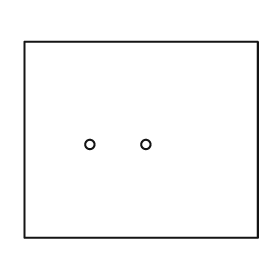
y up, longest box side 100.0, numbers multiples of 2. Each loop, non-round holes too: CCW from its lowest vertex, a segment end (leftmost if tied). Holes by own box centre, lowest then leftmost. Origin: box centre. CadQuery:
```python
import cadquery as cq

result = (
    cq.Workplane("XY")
    .moveTo(-50.0, -42.0)
    .lineTo(50.0, -42.0)
    .lineTo(50.0, 42.0)
    .lineTo(-50.0, 42.0)
    .close()
    .moveTo(-22.0, -2.0)
    .circle(2.0)
    .moveTo(2.0, -2.0)
    .circle(2.0)
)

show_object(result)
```